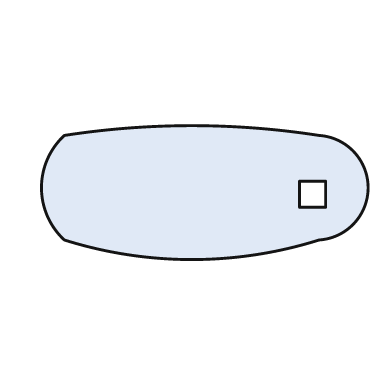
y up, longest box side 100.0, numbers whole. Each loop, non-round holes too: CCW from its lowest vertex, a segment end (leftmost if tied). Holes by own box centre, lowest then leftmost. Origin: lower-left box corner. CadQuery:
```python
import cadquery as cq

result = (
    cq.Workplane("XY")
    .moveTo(7.0, 6.0)
    .threePointArc((46.0, 0.0), (85.0, 6.0))
    .threePointArc((100.0, 22.0), (85.0, 38.0))
    .threePointArc((46.0, 41.0), (7.0, 38.0))
    .threePointArc((0.0, 22.0), (7.0, 6.0))
    .close()
    .moveTo(79.0, 16.0)
    .lineTo(87.0, 16.0)
    .lineTo(87.0, 24.0)
    .lineTo(79.0, 24.0)
    .close()
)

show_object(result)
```